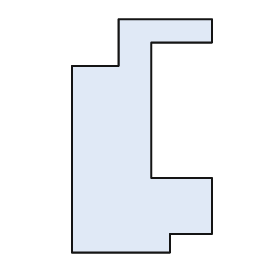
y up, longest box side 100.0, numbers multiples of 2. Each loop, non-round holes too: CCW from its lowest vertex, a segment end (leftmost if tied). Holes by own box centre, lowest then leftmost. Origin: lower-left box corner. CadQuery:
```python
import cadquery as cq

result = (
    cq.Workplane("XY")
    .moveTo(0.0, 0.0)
    .lineTo(42.0, 0.0)
    .lineTo(42.0, 8.0)
    .lineTo(60.0, 8.0)
    .lineTo(60.0, 32.0)
    .lineTo(34.0, 32.0)
    .lineTo(34.0, 90.0)
    .lineTo(60.0, 90.0)
    .lineTo(60.0, 100.0)
    .lineTo(20.0, 100.0)
    .lineTo(20.0, 80.0)
    .lineTo(0.0, 80.0)
    .close()
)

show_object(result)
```